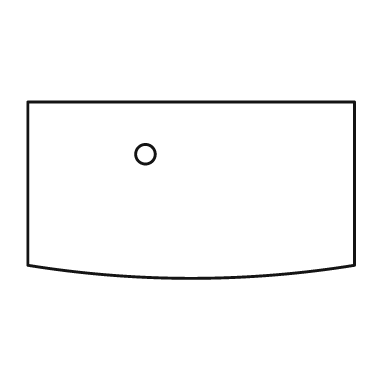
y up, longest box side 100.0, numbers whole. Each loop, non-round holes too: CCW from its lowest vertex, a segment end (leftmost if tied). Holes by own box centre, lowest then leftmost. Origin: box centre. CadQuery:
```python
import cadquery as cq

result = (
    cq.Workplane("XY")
    .moveTo(-50.0, -23.0)
    .threePointArc((0.0, -27.0), (50.0, -23.0))
    .lineTo(50.0, 27.0)
    .lineTo(-50.0, 27.0)
    .close()
    .moveTo(-14.0, 11.0)
    .circle(3.0)
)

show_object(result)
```